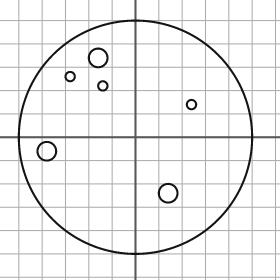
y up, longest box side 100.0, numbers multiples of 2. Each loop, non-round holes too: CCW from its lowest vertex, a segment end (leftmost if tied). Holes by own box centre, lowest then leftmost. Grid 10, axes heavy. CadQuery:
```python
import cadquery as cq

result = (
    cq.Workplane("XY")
    .moveTo(0.0, 0.0)
    .circle(50.0)
    .moveTo(14.0, -24.0)
    .circle(4.0)
    .moveTo(-38.0, -6.0)
    .circle(4.0)
    .moveTo(24.0, 14.0)
    .circle(2.0)
    .moveTo(-14.0, 22.0)
    .circle(2.0)
    .moveTo(-28.0, 26.0)
    .circle(2.0)
    .moveTo(-16.0, 34.0)
    .circle(4.0)
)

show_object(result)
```